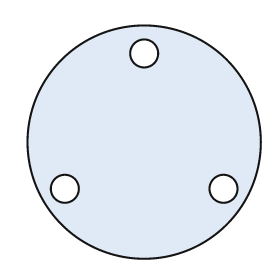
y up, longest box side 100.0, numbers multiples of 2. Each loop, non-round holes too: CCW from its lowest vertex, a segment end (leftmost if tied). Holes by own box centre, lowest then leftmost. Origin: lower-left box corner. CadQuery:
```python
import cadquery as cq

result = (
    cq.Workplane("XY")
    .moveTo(50.0, 50.0)
    .circle(50.0)
    .moveTo(16.0, 30.0)
    .circle(6.0)
    .moveTo(84.0, 30.0)
    .circle(6.0)
    .moveTo(50.0, 88.0)
    .circle(6.0)
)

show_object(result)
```